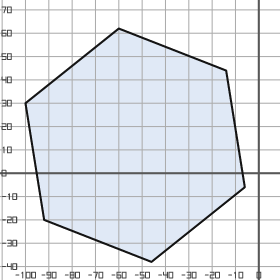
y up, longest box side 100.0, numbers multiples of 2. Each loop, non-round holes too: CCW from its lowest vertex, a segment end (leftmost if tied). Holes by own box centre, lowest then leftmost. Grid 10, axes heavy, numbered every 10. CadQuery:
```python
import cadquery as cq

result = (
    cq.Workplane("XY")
    .moveTo(-46.0, -38.0)
    .lineTo(-6.0, -6.0)
    .lineTo(-14.0, 44.0)
    .lineTo(-60.0, 62.0)
    .lineTo(-100.0, 30.0)
    .lineTo(-92.0, -20.0)
    .close()
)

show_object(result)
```